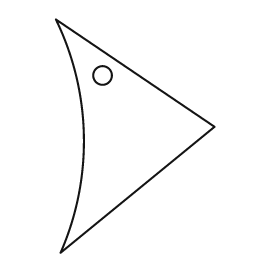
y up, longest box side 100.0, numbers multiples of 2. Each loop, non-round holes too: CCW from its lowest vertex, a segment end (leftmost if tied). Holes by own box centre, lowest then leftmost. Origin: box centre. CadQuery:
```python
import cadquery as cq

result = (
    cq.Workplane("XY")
    .moveTo(-32.0, -50.0)
    .lineTo(34.0, 4.0)
    .lineTo(-34.0, 50.0)
    .threePointArc((-22.0, 0.0), (-32.0, -50.0))
    .close()
    .moveTo(-14.0, 26.0)
    .circle(4.0)
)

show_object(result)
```